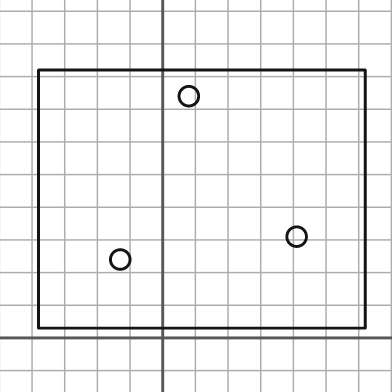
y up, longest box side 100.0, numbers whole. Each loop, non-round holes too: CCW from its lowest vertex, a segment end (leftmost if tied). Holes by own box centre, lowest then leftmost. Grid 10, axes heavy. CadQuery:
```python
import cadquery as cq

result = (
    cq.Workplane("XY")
    .moveTo(-38.0, 3.0)
    .lineTo(62.0, 3.0)
    .lineTo(62.0, 82.0)
    .lineTo(-38.0, 82.0)
    .close()
    .moveTo(-13.0, 24.0)
    .circle(3.0)
    .moveTo(41.0, 31.0)
    .circle(3.0)
    .moveTo(8.0, 74.0)
    .circle(3.0)
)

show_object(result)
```